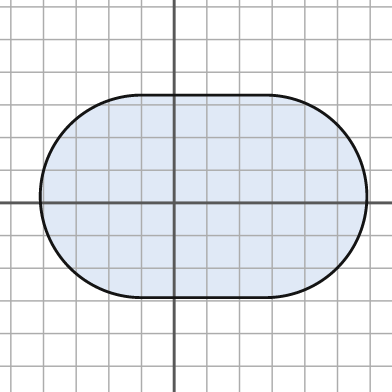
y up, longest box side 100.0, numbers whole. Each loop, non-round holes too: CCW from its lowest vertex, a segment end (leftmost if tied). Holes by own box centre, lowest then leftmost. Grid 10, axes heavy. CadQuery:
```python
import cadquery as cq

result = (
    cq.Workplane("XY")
    .moveTo(-10.0, -29.0)
    .lineTo(28.0, -29.0)
    .threePointArc((59.0, 2.0), (28.0, 33.0))
    .lineTo(-10.0, 33.0)
    .threePointArc((-41.0, 2.0), (-10.0, -29.0))
    .close()
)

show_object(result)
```